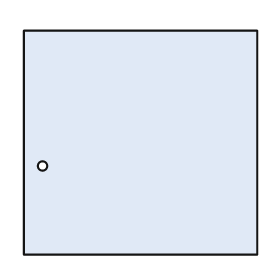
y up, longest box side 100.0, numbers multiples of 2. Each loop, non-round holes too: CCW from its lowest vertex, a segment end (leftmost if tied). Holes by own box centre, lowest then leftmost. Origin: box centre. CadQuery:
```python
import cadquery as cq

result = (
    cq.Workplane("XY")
    .moveTo(-50.0, -48.0)
    .lineTo(50.0, -48.0)
    .lineTo(50.0, 48.0)
    .lineTo(-50.0, 48.0)
    .close()
    .moveTo(-42.0, -10.0)
    .circle(2.0)
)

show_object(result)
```